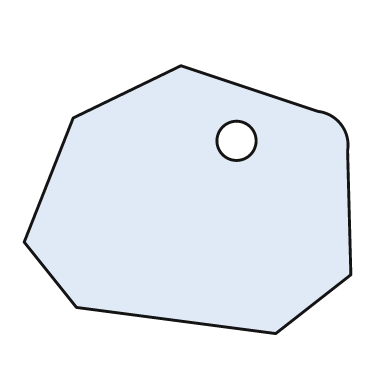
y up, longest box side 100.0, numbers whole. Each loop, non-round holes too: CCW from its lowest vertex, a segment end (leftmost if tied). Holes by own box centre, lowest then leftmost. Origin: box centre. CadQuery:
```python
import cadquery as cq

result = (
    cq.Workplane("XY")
    .moveTo(27.0, -41.0)
    .lineTo(50.0, -23.0)
    .lineTo(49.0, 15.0)
    .threePointArc((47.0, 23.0), (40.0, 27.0))
    .lineTo(-2.0, 41.0)
    .lineTo(-35.0, 25.0)
    .lineTo(-50.0, -13.0)
    .lineTo(-34.0, -33.0)
    .close()
    .moveTo(15.0, 18.0)
    .circle(6.0)
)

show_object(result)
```